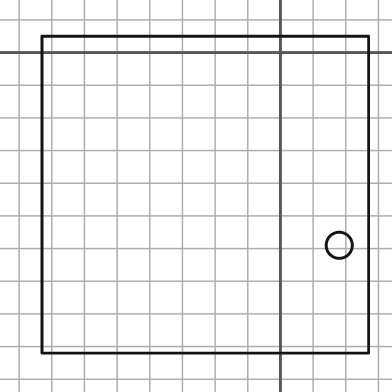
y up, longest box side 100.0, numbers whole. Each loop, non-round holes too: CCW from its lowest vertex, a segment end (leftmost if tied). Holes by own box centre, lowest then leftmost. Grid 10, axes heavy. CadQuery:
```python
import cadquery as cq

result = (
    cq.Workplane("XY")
    .moveTo(-73.0, -92.0)
    .lineTo(27.0, -92.0)
    .lineTo(27.0, 5.0)
    .lineTo(-73.0, 5.0)
    .close()
    .moveTo(18.0, -59.0)
    .circle(4.0)
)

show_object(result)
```